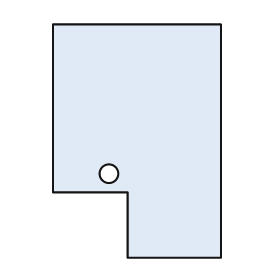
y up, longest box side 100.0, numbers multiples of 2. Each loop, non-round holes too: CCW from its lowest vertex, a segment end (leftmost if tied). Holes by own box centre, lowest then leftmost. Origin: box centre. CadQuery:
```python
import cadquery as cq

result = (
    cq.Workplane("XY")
    .moveTo(-4.0, -50.0)
    .lineTo(36.0, -50.0)
    .lineTo(36.0, 50.0)
    .lineTo(-36.0, 50.0)
    .lineTo(-36.0, -22.0)
    .lineTo(-4.0, -22.0)
    .close()
    .moveTo(-12.0, -14.0)
    .circle(4.0)
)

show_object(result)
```